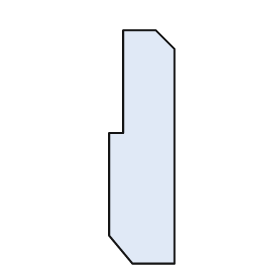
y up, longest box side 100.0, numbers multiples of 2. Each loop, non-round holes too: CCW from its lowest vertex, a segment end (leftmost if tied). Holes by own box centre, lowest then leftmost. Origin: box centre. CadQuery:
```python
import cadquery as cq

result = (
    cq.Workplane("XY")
    .moveTo(-4.0, -50.0)
    .lineTo(14.0, -50.0)
    .lineTo(14.0, 42.0)
    .lineTo(6.0, 50.0)
    .lineTo(-8.0, 50.0)
    .lineTo(-8.0, 6.0)
    .lineTo(-14.0, 6.0)
    .lineTo(-14.0, -38.0)
    .close()
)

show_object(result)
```